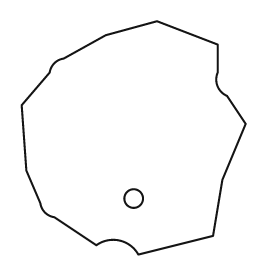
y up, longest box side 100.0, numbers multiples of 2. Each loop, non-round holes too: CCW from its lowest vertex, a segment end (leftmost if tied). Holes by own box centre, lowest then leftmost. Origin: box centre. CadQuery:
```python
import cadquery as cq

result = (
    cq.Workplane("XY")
    .moveTo(2.0, -50.0)
    .lineTo(34.0, -42.0)
    .lineTo(38.0, -18.0)
    .lineTo(48.0, 6.0)
    .lineTo(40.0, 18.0)
    .threePointArc((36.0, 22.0), (36.0, 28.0))
    .lineTo(36.0, 40.0)
    .lineTo(10.0, 50.0)
    .lineTo(-12.0, 44.0)
    .lineTo(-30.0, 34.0)
    .threePointArc((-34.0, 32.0), (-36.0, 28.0))
    .lineTo(-48.0, 14.0)
    .lineTo(-46.0, -14.0)
    .lineTo(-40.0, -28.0)
    .threePointArc((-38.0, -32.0), (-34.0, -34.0))
    .lineTo(-16.0, -46.0)
    .threePointArc((-6.0, -44.0), (2.0, -50.0))
    .close()
    .moveTo(0.0, -26.0)
    .circle(4.0)
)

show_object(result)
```